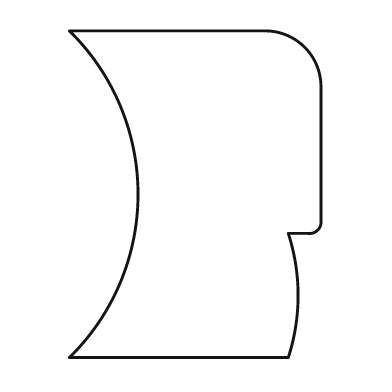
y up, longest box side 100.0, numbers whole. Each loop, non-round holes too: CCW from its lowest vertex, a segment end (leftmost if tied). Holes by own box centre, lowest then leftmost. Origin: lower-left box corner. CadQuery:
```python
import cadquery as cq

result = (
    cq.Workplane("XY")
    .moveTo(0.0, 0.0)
    .lineTo(67.0, 0.0)
    .threePointArc((70.0, 19.0), (67.0, 38.0))
    .lineTo(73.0, 38.0)
    .threePointArc((76.0, 39.0), (77.0, 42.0))
    .lineTo(77.0, 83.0)
    .threePointArc((72.0, 95.0), (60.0, 100.0))
    .lineTo(0.0, 100.0)
    .threePointArc((21.0, 50.0), (0.0, 0.0))
    .close()
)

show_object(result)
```